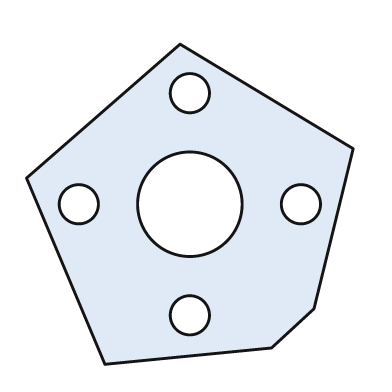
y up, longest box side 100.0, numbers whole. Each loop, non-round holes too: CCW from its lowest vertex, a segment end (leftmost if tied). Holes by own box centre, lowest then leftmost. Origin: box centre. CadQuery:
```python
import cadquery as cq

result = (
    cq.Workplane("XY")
    .moveTo(-26.0, -49.0)
    .lineTo(25.0, -44.0)
    .lineTo(38.0, -32.0)
    .lineTo(50.0, 17.0)
    .lineTo(-3.0, 49.0)
    .lineTo(-50.0, 8.0)
    .close()
    .moveTo(0.0, -34.0)
    .circle(6.0)
    .moveTo(-34.0, 0.0)
    .circle(6.0)
    .moveTo(0.0, 0.0)
    .circle(16.0)
    .moveTo(34.0, 0.0)
    .circle(6.0)
    .moveTo(0.0, 34.0)
    .circle(6.0)
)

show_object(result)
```